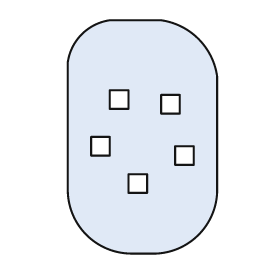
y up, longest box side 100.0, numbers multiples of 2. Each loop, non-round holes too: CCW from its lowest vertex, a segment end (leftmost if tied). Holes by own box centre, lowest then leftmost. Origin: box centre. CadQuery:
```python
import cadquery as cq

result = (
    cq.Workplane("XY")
    .moveTo(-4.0, -50.0)
    .lineTo(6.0, -50.0)
    .threePointArc((24.0, -42.0), (32.0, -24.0))
    .lineTo(32.0, 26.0)
    .threePointArc((24.0, 42.0), (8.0, 50.0))
    .lineTo(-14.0, 50.0)
    .threePointArc((-26.0, 44.0), (-32.0, 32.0))
    .lineTo(-32.0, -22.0)
    .threePointArc((-24.0, -42.0), (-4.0, -50.0))
    .close()
    .moveTo(-6.0, -24.0)
    .lineTo(2.0, -24.0)
    .lineTo(2.0, -16.0)
    .lineTo(-6.0, -16.0)
    .close()
    .moveTo(14.0, -12.0)
    .lineTo(22.0, -12.0)
    .lineTo(22.0, -4.0)
    .lineTo(14.0, -4.0)
    .close()
    .moveTo(-22.0, -8.0)
    .lineTo(-14.0, -8.0)
    .lineTo(-14.0, 0.0)
    .lineTo(-22.0, 0.0)
    .close()
    .moveTo(8.0, 10.0)
    .lineTo(16.0, 10.0)
    .lineTo(16.0, 18.0)
    .lineTo(8.0, 18.0)
    .close()
    .moveTo(-14.0, 12.0)
    .lineTo(-6.0, 12.0)
    .lineTo(-6.0, 20.0)
    .lineTo(-14.0, 20.0)
    .close()
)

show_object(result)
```